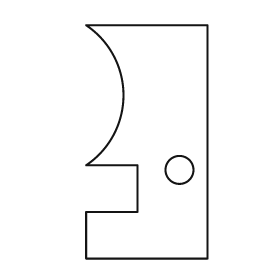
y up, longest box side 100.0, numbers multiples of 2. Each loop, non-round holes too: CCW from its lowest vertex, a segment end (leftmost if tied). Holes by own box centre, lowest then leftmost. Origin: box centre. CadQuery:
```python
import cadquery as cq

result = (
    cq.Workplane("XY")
    .moveTo(-26.0, -50.0)
    .lineTo(26.0, -50.0)
    .lineTo(26.0, 50.0)
    .lineTo(-26.0, 50.0)
    .threePointArc((-10.0, 20.0), (-26.0, -10.0))
    .lineTo(-4.0, -10.0)
    .lineTo(-4.0, -30.0)
    .lineTo(-26.0, -30.0)
    .close()
    .moveTo(14.0, -12.0)
    .circle(6.0)
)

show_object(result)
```